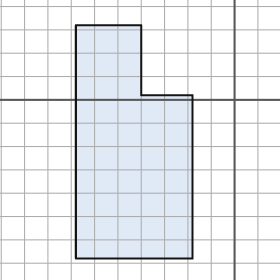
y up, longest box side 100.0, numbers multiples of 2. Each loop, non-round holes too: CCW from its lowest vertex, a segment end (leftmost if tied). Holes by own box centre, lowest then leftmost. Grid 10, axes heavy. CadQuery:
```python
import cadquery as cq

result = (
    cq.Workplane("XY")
    .moveTo(-68.0, -68.0)
    .lineTo(-18.0, -68.0)
    .lineTo(-18.0, 2.0)
    .lineTo(-40.0, 2.0)
    .lineTo(-40.0, 32.0)
    .lineTo(-68.0, 32.0)
    .close()
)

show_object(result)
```